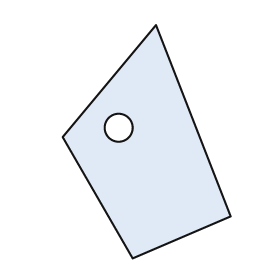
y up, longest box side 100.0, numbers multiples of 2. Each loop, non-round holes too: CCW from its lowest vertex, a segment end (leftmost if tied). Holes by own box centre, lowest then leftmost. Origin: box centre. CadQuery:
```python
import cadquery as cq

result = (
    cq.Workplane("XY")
    .moveTo(-6.0, -50.0)
    .lineTo(36.0, -32.0)
    .lineTo(4.0, 50.0)
    .lineTo(-36.0, 2.0)
    .close()
    .moveTo(-12.0, 6.0)
    .circle(6.0)
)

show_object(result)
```